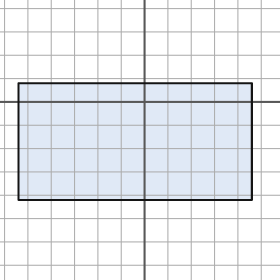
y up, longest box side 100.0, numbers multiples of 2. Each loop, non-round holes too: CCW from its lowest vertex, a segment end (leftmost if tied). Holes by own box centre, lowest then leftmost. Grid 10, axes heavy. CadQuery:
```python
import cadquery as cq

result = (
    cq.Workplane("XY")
    .moveTo(-54.0, -42.0)
    .lineTo(46.0, -42.0)
    .lineTo(46.0, 8.0)
    .lineTo(-54.0, 8.0)
    .close()
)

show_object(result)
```